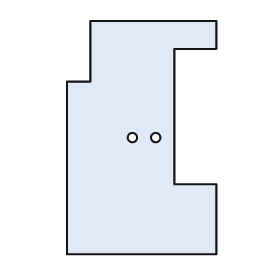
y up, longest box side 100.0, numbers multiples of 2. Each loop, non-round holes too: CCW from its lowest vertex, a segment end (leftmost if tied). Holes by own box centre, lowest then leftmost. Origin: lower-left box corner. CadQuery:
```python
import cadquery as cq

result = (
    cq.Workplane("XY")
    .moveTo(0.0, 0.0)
    .lineTo(64.0, 0.0)
    .lineTo(64.0, 30.0)
    .lineTo(46.0, 30.0)
    .lineTo(46.0, 88.0)
    .lineTo(64.0, 88.0)
    .lineTo(64.0, 100.0)
    .lineTo(10.0, 100.0)
    .lineTo(10.0, 74.0)
    .lineTo(0.0, 74.0)
    .close()
    .moveTo(28.0, 50.0)
    .circle(2.0)
    .moveTo(38.0, 50.0)
    .circle(2.0)
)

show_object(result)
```